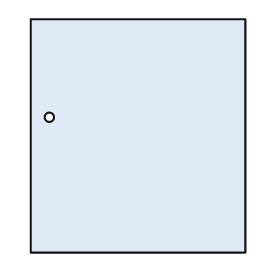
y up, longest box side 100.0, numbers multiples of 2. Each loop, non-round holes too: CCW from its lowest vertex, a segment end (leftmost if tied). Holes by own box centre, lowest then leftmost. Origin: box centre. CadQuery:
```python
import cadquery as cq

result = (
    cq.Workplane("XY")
    .moveTo(-46.0, -50.0)
    .lineTo(46.0, -50.0)
    .lineTo(46.0, 50.0)
    .lineTo(-46.0, 50.0)
    .close()
    .moveTo(-38.0, 8.0)
    .circle(2.0)
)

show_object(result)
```